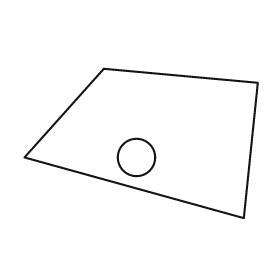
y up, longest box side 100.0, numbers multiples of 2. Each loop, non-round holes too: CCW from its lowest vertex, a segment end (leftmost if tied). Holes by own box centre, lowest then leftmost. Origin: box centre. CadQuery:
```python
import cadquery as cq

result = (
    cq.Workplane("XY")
    .moveTo(44.0, -32.0)
    .lineTo(50.0, 26.0)
    .lineTo(-16.0, 32.0)
    .lineTo(-50.0, -6.0)
    .close()
    .moveTo(-2.0, -6.0)
    .circle(8.0)
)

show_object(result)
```